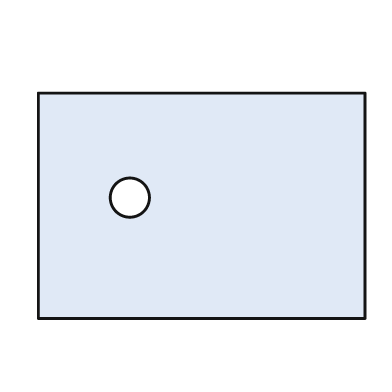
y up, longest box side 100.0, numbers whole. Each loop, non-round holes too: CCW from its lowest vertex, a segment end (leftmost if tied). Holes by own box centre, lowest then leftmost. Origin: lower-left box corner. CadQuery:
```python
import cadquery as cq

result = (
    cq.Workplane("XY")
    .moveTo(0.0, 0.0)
    .lineTo(100.0, 0.0)
    .lineTo(100.0, 69.0)
    .lineTo(0.0, 69.0)
    .close()
    .moveTo(28.0, 37.0)
    .circle(6.0)
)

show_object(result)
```